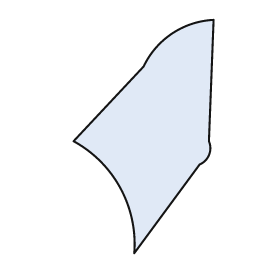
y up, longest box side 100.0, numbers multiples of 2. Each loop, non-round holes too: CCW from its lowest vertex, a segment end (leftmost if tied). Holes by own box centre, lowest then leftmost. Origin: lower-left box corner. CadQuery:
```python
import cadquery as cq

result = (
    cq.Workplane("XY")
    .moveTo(26.0, 0.0)
    .lineTo(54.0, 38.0)
    .threePointArc((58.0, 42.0), (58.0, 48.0))
    .lineTo(60.0, 100.0)
    .threePointArc((42.0, 94.0), (30.0, 80.0))
    .lineTo(0.0, 48.0)
    .threePointArc((20.0, 28.0), (26.0, 0.0))
    .close()
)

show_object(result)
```